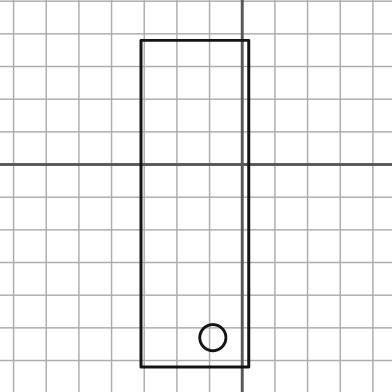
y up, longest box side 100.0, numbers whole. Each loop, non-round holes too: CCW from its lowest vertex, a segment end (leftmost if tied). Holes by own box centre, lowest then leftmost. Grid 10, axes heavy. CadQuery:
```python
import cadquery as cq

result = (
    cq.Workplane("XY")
    .moveTo(-31.0, -62.0)
    .lineTo(2.0, -62.0)
    .lineTo(2.0, 38.0)
    .lineTo(-31.0, 38.0)
    .close()
    .moveTo(-9.0, -53.0)
    .circle(4.0)
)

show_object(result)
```